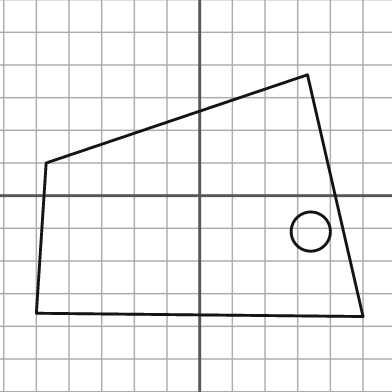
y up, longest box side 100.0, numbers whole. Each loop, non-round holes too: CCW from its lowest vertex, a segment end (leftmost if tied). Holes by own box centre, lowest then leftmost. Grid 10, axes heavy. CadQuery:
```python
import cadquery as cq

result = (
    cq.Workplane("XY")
    .moveTo(50.0, -37.0)
    .lineTo(33.0, 37.0)
    .lineTo(-47.0, 10.0)
    .lineTo(-50.0, -36.0)
    .close()
    .moveTo(34.0, -11.0)
    .circle(6.0)
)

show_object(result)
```